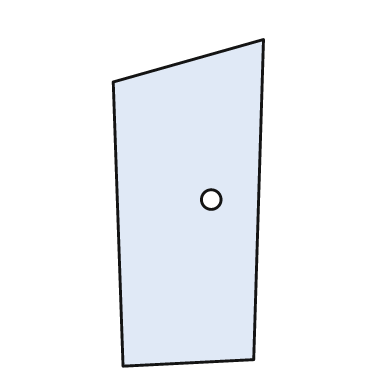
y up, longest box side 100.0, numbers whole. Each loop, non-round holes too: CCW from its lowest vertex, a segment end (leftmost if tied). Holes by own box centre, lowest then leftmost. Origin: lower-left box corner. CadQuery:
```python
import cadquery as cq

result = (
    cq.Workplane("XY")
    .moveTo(3.0, 0.0)
    .lineTo(43.0, 2.0)
    .lineTo(46.0, 100.0)
    .lineTo(0.0, 87.0)
    .close()
    .moveTo(30.0, 51.0)
    .circle(3.0)
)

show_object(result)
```